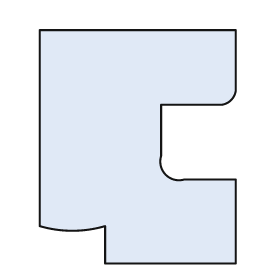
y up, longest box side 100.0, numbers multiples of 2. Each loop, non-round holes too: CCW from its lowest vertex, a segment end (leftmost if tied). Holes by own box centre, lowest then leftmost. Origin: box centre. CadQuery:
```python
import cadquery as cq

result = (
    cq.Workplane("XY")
    .moveTo(-14.0, -50.0)
    .lineTo(42.0, -50.0)
    .lineTo(42.0, -14.0)
    .lineTo(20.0, -14.0)
    .threePointArc((12.0, -12.0), (10.0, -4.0))
    .lineTo(10.0, 18.0)
    .lineTo(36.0, 18.0)
    .threePointArc((40.0, 20.0), (42.0, 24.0))
    .lineTo(42.0, 50.0)
    .lineTo(-42.0, 50.0)
    .lineTo(-42.0, -34.0)
    .threePointArc((-28.0, -36.0), (-14.0, -34.0))
    .close()
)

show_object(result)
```